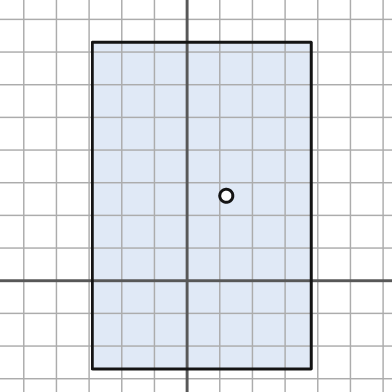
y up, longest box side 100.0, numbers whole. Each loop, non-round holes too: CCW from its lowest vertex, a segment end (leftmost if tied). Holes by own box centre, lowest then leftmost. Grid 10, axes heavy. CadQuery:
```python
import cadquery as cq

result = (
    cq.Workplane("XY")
    .moveTo(-29.0, -27.0)
    .lineTo(38.0, -27.0)
    .lineTo(38.0, 73.0)
    .lineTo(-29.0, 73.0)
    .close()
    .moveTo(12.0, 26.0)
    .circle(2.0)
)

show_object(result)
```